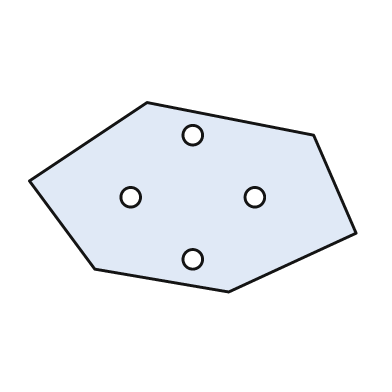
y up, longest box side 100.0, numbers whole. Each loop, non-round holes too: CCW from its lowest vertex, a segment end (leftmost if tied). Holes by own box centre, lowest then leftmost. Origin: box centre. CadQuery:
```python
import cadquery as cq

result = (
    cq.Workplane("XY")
    .moveTo(11.0, -29.0)
    .lineTo(50.0, -11.0)
    .lineTo(37.0, 19.0)
    .lineTo(-14.0, 29.0)
    .lineTo(-50.0, 5.0)
    .lineTo(-30.0, -22.0)
    .close()
    .moveTo(0.0, -19.0)
    .circle(3.0)
    .moveTo(-19.0, 0.0)
    .circle(3.0)
    .moveTo(19.0, 0.0)
    .circle(3.0)
    .moveTo(0.0, 19.0)
    .circle(3.0)
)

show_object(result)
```